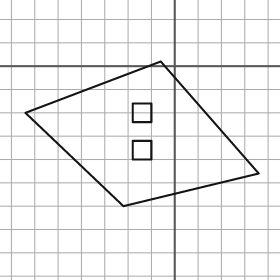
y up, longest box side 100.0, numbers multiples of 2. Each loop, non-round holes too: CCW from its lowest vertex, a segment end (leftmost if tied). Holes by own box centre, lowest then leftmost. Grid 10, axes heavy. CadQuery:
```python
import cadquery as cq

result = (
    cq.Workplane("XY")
    .moveTo(-22.0, -60.0)
    .lineTo(36.0, -46.0)
    .lineTo(-6.0, 2.0)
    .lineTo(-64.0, -20.0)
    .close()
    .moveTo(-18.0, -40.0)
    .lineTo(-10.0, -40.0)
    .lineTo(-10.0, -32.0)
    .lineTo(-18.0, -32.0)
    .close()
    .moveTo(-18.0, -24.0)
    .lineTo(-10.0, -24.0)
    .lineTo(-10.0, -16.0)
    .lineTo(-18.0, -16.0)
    .close()
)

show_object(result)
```